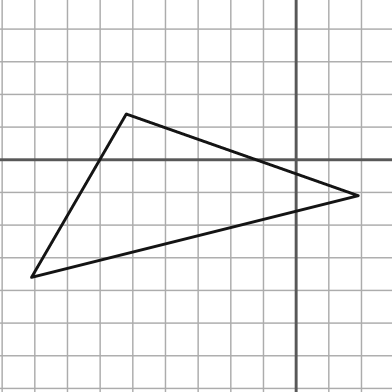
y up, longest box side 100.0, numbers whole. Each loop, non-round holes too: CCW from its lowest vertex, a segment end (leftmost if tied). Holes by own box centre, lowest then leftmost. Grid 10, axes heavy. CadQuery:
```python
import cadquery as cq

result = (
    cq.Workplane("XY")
    .moveTo(-81.0, -36.0)
    .lineTo(19.0, -11.0)
    .lineTo(-52.0, 14.0)
    .close()
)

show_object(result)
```